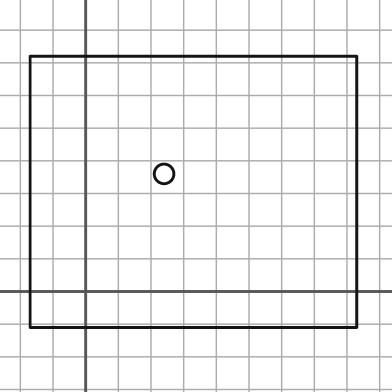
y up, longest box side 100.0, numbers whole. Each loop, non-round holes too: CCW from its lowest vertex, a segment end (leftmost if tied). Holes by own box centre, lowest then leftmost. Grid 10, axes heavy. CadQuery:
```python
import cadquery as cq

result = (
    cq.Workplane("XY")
    .moveTo(-17.0, -11.0)
    .lineTo(83.0, -11.0)
    .lineTo(83.0, 72.0)
    .lineTo(-17.0, 72.0)
    .close()
    .moveTo(24.0, 36.0)
    .circle(3.0)
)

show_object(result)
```